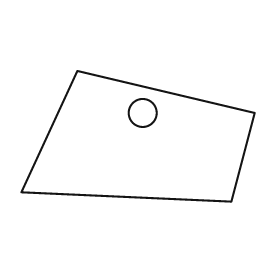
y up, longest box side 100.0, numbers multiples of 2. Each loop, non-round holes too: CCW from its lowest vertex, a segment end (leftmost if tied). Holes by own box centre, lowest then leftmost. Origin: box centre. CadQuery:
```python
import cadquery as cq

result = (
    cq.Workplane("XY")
    .moveTo(40.0, -28.0)
    .lineTo(50.0, 10.0)
    .lineTo(-26.0, 28.0)
    .lineTo(-50.0, -24.0)
    .close()
    .moveTo(2.0, 10.0)
    .circle(6.0)
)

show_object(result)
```